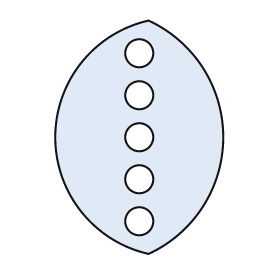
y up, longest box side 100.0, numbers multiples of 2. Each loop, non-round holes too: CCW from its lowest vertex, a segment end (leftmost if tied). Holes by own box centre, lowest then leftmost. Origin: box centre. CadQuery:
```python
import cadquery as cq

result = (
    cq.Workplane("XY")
    .moveTo(4.0, -50.0)
    .threePointArc((36.0, 0.0), (4.0, 50.0))
    .threePointArc((-36.0, 0.0), (4.0, -50.0))
    .close()
    .moveTo(0.0, -36.0)
    .circle(6.0)
    .moveTo(0.0, -18.0)
    .circle(6.0)
    .moveTo(0.0, 0.0)
    .circle(6.0)
    .moveTo(0.0, 18.0)
    .circle(6.0)
    .moveTo(0.0, 36.0)
    .circle(6.0)
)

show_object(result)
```